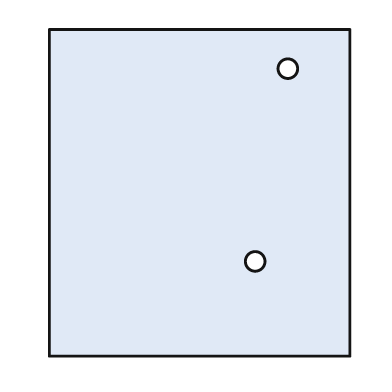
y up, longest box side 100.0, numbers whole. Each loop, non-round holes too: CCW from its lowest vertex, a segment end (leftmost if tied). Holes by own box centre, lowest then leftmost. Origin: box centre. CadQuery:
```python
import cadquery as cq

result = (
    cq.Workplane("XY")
    .moveTo(-46.0, -50.0)
    .lineTo(46.0, -50.0)
    .lineTo(46.0, 50.0)
    .lineTo(-46.0, 50.0)
    .close()
    .moveTo(17.0, -21.0)
    .circle(3.0)
    .moveTo(27.0, 38.0)
    .circle(3.0)
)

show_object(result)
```